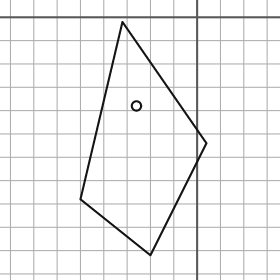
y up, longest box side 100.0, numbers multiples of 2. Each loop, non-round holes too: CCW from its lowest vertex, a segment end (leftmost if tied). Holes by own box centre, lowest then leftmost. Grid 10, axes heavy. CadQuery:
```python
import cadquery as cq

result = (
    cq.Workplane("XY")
    .moveTo(-20.0, -102.0)
    .lineTo(4.0, -54.0)
    .lineTo(-32.0, -2.0)
    .lineTo(-50.0, -78.0)
    .close()
    .moveTo(-26.0, -38.0)
    .circle(2.0)
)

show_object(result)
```